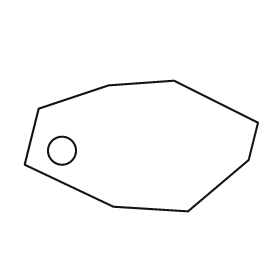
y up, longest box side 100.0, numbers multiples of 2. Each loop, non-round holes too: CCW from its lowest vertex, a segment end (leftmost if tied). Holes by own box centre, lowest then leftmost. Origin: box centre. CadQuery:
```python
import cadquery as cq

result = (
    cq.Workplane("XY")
    .moveTo(20.0, -28.0)
    .lineTo(46.0, -6.0)
    .lineTo(50.0, 10.0)
    .lineTo(14.0, 28.0)
    .lineTo(-14.0, 26.0)
    .lineTo(-44.0, 16.0)
    .lineTo(-50.0, -8.0)
    .lineTo(-12.0, -26.0)
    .close()
    .moveTo(-34.0, -2.0)
    .circle(6.0)
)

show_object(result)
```